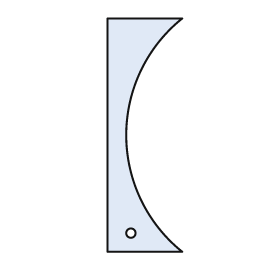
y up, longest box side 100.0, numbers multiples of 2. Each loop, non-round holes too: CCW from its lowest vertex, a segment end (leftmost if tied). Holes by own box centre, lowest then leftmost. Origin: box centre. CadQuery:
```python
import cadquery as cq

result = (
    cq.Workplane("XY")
    .moveTo(-16.0, -50.0)
    .lineTo(16.0, -50.0)
    .threePointArc((-8.0, 0.0), (16.0, 50.0))
    .lineTo(-16.0, 50.0)
    .close()
    .moveTo(-6.0, -42.0)
    .circle(2.0)
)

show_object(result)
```